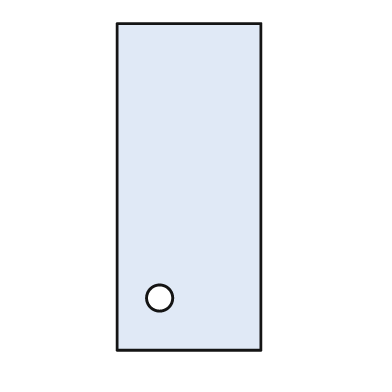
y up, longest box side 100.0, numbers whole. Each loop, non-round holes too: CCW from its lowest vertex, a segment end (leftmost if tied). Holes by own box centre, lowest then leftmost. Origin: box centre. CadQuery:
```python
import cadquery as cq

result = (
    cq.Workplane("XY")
    .moveTo(-22.0, -50.0)
    .lineTo(22.0, -50.0)
    .lineTo(22.0, 50.0)
    .lineTo(-22.0, 50.0)
    .close()
    .moveTo(-9.0, -34.0)
    .circle(4.0)
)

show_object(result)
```